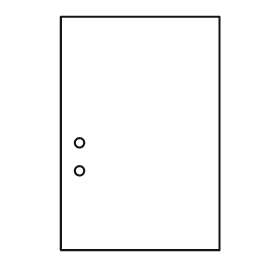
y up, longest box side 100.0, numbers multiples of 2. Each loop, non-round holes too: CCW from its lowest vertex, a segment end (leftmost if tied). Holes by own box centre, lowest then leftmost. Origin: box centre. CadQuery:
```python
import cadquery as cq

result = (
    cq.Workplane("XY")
    .moveTo(-34.0, -50.0)
    .lineTo(34.0, -50.0)
    .lineTo(34.0, 50.0)
    .lineTo(-34.0, 50.0)
    .close()
    .moveTo(-26.0, -16.0)
    .circle(2.0)
    .moveTo(-26.0, -4.0)
    .circle(2.0)
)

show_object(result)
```